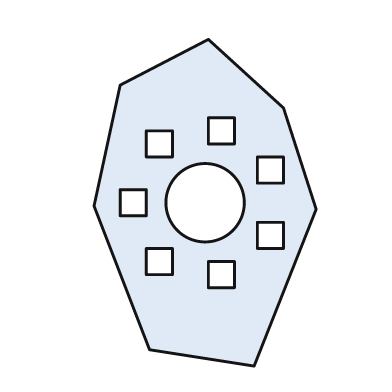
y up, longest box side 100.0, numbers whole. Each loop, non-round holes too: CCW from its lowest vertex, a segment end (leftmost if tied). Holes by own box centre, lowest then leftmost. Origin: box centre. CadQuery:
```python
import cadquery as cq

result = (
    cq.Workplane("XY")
    .moveTo(15.0, -50.0)
    .lineTo(34.0, -2.0)
    .lineTo(24.0, 29.0)
    .lineTo(1.0, 50.0)
    .lineTo(-26.0, 36.0)
    .lineTo(-34.0, -1.0)
    .lineTo(-17.0, -45.0)
    .close()
    .moveTo(1.0, -26.0)
    .lineTo(9.0, -26.0)
    .lineTo(9.0, -18.0)
    .lineTo(1.0, -18.0)
    .close()
    .moveTo(-18.0, -22.0)
    .lineTo(-10.0, -22.0)
    .lineTo(-10.0, -14.0)
    .lineTo(-18.0, -14.0)
    .close()
    .moveTo(16.0, -14.0)
    .lineTo(24.0, -14.0)
    .lineTo(24.0, -6.0)
    .lineTo(16.0, -6.0)
    .close()
    .moveTo(-26.0, -4.0)
    .lineTo(-18.0, -4.0)
    .lineTo(-18.0, 4.0)
    .lineTo(-26.0, 4.0)
    .close()
    .moveTo(0.0, 0.0)
    .circle(12.0)
    .moveTo(16.0, 6.0)
    .lineTo(24.0, 6.0)
    .lineTo(24.0, 14.0)
    .lineTo(16.0, 14.0)
    .close()
    .moveTo(-18.0, 14.0)
    .lineTo(-10.0, 14.0)
    .lineTo(-10.0, 22.0)
    .lineTo(-18.0, 22.0)
    .close()
    .moveTo(1.0, 18.0)
    .lineTo(9.0, 18.0)
    .lineTo(9.0, 26.0)
    .lineTo(1.0, 26.0)
    .close()
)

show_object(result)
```